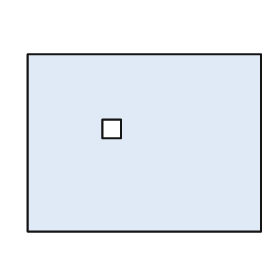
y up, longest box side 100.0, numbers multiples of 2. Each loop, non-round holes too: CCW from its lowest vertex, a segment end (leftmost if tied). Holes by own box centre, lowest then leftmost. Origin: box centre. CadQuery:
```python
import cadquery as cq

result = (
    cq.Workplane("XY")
    .moveTo(-50.0, -38.0)
    .lineTo(50.0, -38.0)
    .lineTo(50.0, 38.0)
    .lineTo(-50.0, 38.0)
    .close()
    .moveTo(-18.0, 2.0)
    .lineTo(-10.0, 2.0)
    .lineTo(-10.0, 10.0)
    .lineTo(-18.0, 10.0)
    .close()
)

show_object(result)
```